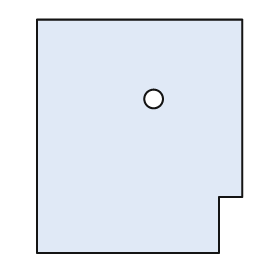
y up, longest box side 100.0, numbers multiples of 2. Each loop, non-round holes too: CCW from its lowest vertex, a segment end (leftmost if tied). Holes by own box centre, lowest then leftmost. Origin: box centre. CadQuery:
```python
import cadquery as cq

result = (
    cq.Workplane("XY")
    .moveTo(-44.0, -50.0)
    .lineTo(34.0, -50.0)
    .lineTo(34.0, -26.0)
    .lineTo(44.0, -26.0)
    .lineTo(44.0, 50.0)
    .lineTo(-44.0, 50.0)
    .close()
    .moveTo(6.0, 16.0)
    .circle(4.0)
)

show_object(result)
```